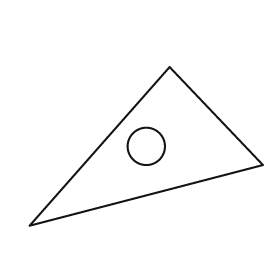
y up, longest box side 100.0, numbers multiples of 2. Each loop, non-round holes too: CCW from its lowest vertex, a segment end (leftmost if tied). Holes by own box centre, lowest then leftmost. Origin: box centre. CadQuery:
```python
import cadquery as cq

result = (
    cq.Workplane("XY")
    .moveTo(-50.0, -34.0)
    .lineTo(50.0, -8.0)
    .lineTo(10.0, 34.0)
    .close()
    .moveTo(0.0, 0.0)
    .circle(8.0)
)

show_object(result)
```